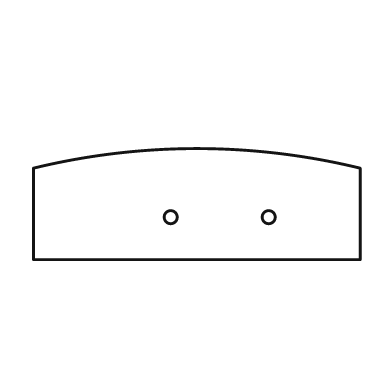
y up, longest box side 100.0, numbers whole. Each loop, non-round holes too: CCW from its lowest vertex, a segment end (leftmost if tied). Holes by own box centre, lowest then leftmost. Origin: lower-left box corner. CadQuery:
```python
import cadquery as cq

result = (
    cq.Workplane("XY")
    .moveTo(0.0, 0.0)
    .lineTo(100.0, 0.0)
    .lineTo(100.0, 28.0)
    .threePointArc((50.0, 34.0), (0.0, 28.0))
    .close()
    .moveTo(42.0, 13.0)
    .circle(2.0)
    .moveTo(72.0, 13.0)
    .circle(2.0)
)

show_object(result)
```